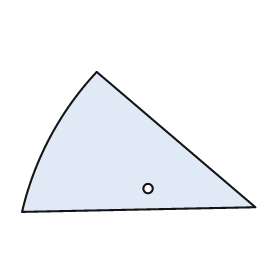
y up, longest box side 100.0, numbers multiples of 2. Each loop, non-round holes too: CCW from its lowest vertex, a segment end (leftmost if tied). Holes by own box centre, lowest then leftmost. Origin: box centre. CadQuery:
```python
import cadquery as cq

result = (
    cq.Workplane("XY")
    .moveTo(-50.0, -30.0)
    .lineTo(50.0, -28.0)
    .lineTo(-18.0, 30.0)
    .threePointArc((-38.0, 2.0), (-50.0, -30.0))
    .close()
    .moveTo(4.0, -20.0)
    .circle(2.0)
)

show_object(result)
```